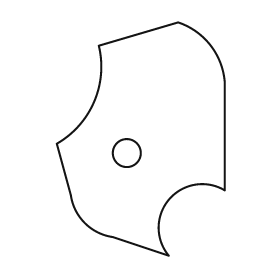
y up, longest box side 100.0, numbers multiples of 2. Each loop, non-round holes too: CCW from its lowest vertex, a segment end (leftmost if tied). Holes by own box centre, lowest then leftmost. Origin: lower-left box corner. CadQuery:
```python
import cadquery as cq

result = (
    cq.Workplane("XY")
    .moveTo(48.0, 0.0)
    .threePointArc((48.0, 24.0), (72.0, 28.0))
    .lineTo(72.0, 74.0)
    .threePointArc((66.0, 90.0), (52.0, 100.0))
    .lineTo(18.0, 90.0)
    .threePointArc((16.0, 66.0), (0.0, 48.0))
    .lineTo(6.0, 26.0)
    .threePointArc((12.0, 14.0), (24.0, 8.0))
    .close()
    .moveTo(30.0, 44.0)
    .circle(6.0)
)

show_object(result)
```